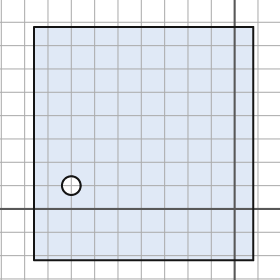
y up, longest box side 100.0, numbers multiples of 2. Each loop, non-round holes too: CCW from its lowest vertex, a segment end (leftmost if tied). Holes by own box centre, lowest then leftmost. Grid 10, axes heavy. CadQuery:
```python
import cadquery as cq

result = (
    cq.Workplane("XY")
    .moveTo(-86.0, -22.0)
    .lineTo(8.0, -22.0)
    .lineTo(8.0, 78.0)
    .lineTo(-86.0, 78.0)
    .close()
    .moveTo(-70.0, 10.0)
    .circle(4.0)
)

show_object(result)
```